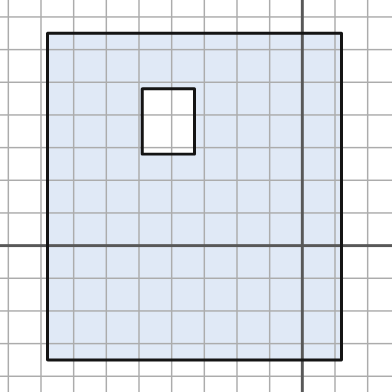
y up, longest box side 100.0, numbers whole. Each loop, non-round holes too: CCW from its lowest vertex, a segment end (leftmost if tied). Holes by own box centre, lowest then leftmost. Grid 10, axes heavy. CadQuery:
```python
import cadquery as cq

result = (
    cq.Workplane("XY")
    .moveTo(-78.0, -35.0)
    .lineTo(12.0, -35.0)
    .lineTo(12.0, 65.0)
    .lineTo(-78.0, 65.0)
    .close()
    .moveTo(-49.0, 28.0)
    .lineTo(-33.0, 28.0)
    .lineTo(-33.0, 48.0)
    .lineTo(-49.0, 48.0)
    .close()
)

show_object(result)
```